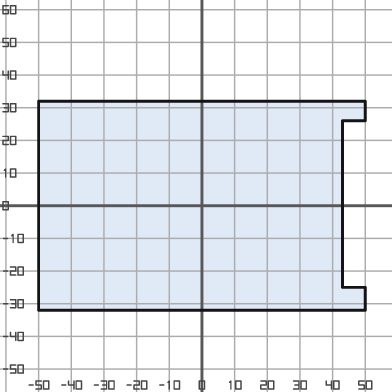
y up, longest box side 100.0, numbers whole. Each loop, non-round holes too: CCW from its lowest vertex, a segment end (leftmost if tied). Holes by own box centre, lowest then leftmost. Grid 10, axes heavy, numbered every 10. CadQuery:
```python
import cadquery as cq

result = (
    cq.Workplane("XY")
    .moveTo(-50.0, -32.0)
    .lineTo(50.0, -32.0)
    .lineTo(50.0, -25.0)
    .lineTo(43.0, -25.0)
    .lineTo(43.0, 26.0)
    .lineTo(50.0, 26.0)
    .lineTo(50.0, 32.0)
    .lineTo(-50.0, 32.0)
    .close()
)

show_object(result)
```